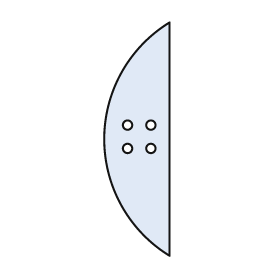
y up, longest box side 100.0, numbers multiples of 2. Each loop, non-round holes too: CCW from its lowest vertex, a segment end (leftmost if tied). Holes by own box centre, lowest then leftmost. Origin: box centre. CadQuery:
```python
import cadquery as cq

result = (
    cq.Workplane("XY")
    .moveTo(14.0, -50.0)
    .lineTo(14.0, 50.0)
    .threePointArc((-14.0, 0.0), (14.0, -50.0))
    .close()
    .moveTo(-4.0, -4.0)
    .circle(2.0)
    .moveTo(6.0, -4.0)
    .circle(2.0)
    .moveTo(-4.0, 6.0)
    .circle(2.0)
    .moveTo(6.0, 6.0)
    .circle(2.0)
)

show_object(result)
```